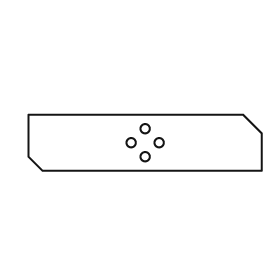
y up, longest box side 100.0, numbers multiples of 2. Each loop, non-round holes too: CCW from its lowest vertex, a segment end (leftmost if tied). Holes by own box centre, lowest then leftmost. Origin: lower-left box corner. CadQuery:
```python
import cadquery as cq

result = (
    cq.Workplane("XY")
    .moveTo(6.0, 0.0)
    .lineTo(100.0, 0.0)
    .lineTo(100.0, 16.0)
    .lineTo(92.0, 24.0)
    .lineTo(0.0, 24.0)
    .lineTo(0.0, 6.0)
    .close()
    .moveTo(50.0, 6.0)
    .circle(2.0)
    .moveTo(44.0, 12.0)
    .circle(2.0)
    .moveTo(56.0, 12.0)
    .circle(2.0)
    .moveTo(50.0, 18.0)
    .circle(2.0)
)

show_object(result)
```